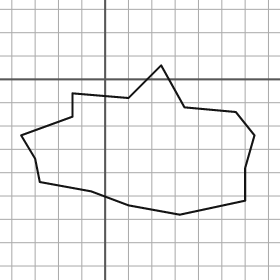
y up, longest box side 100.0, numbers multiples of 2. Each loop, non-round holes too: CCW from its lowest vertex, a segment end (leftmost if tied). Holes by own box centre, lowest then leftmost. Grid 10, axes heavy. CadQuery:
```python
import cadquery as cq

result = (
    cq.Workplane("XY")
    .moveTo(32.0, -58.0)
    .lineTo(60.0, -52.0)
    .lineTo(60.0, -38.0)
    .lineTo(64.0, -24.0)
    .lineTo(56.0, -14.0)
    .lineTo(34.0, -12.0)
    .lineTo(24.0, 6.0)
    .lineTo(10.0, -8.0)
    .lineTo(-14.0, -6.0)
    .lineTo(-14.0, -16.0)
    .lineTo(-36.0, -24.0)
    .lineTo(-30.0, -34.0)
    .lineTo(-28.0, -44.0)
    .lineTo(-6.0, -48.0)
    .lineTo(10.0, -54.0)
    .close()
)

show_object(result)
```